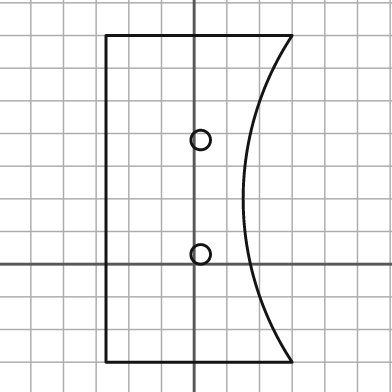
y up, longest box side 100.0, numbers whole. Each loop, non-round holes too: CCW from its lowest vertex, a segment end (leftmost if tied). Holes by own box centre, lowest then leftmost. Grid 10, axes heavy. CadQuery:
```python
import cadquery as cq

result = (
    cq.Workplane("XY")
    .moveTo(-27.0, -30.0)
    .lineTo(30.0, -30.0)
    .threePointArc((15.0, 20.0), (30.0, 70.0))
    .lineTo(-27.0, 70.0)
    .close()
    .moveTo(2.0, 3.0)
    .circle(3.0)
    .moveTo(2.0, 38.0)
    .circle(3.0)
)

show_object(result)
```